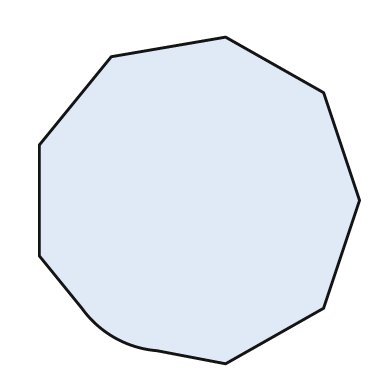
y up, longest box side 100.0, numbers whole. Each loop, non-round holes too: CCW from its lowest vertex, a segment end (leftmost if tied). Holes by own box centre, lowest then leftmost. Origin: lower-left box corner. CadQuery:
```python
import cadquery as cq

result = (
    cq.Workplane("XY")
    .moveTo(57.0, 0.0)
    .lineTo(87.0, 17.0)
    .lineTo(98.0, 50.0)
    .lineTo(87.0, 83.0)
    .lineTo(57.0, 100.0)
    .lineTo(22.0, 94.0)
    .lineTo(0.0, 67.0)
    .lineTo(0.0, 33.0)
    .lineTo(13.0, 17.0)
    .threePointArc((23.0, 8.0), (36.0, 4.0))
    .close()
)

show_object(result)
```